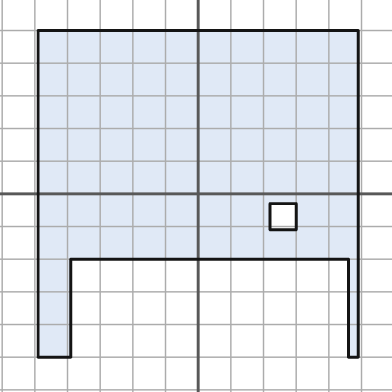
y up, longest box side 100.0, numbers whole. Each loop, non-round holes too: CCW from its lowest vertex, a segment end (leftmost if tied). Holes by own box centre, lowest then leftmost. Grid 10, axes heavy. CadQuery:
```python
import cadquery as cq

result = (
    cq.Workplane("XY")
    .moveTo(-49.0, -50.0)
    .lineTo(-39.0, -50.0)
    .lineTo(-39.0, -20.0)
    .lineTo(46.0, -20.0)
    .lineTo(46.0, -50.0)
    .lineTo(49.0, -50.0)
    .lineTo(49.0, 50.0)
    .lineTo(-49.0, 50.0)
    .close()
    .moveTo(22.0, -11.0)
    .lineTo(30.0, -11.0)
    .lineTo(30.0, -3.0)
    .lineTo(22.0, -3.0)
    .close()
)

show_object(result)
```